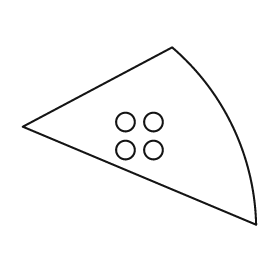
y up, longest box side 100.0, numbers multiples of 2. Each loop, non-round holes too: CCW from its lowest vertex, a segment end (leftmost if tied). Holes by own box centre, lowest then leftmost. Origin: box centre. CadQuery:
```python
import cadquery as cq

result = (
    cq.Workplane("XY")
    .moveTo(50.0, -38.0)
    .threePointArc((40.0, 4.0), (14.0, 38.0))
    .lineTo(-50.0, 4.0)
    .close()
    .moveTo(-6.0, -6.0)
    .circle(4.0)
    .moveTo(6.0, -6.0)
    .circle(4.0)
    .moveTo(-6.0, 6.0)
    .circle(4.0)
    .moveTo(6.0, 6.0)
    .circle(4.0)
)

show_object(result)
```